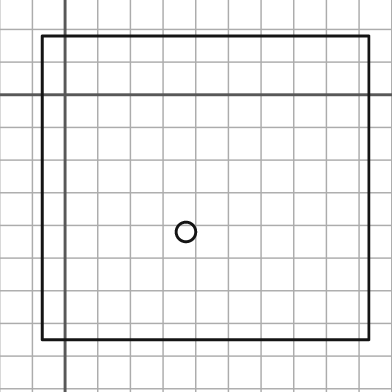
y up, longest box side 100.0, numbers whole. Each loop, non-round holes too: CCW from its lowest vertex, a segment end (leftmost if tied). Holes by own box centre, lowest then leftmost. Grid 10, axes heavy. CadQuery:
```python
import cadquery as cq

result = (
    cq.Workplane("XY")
    .moveTo(-7.0, -75.0)
    .lineTo(93.0, -75.0)
    .lineTo(93.0, 18.0)
    .lineTo(-7.0, 18.0)
    .close()
    .moveTo(37.0, -42.0)
    .circle(3.0)
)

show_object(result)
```